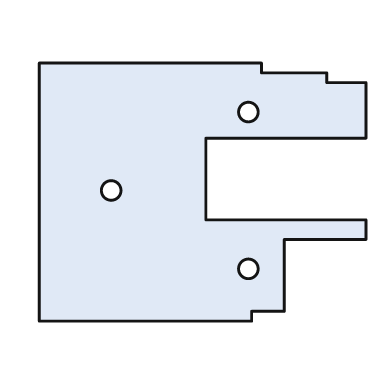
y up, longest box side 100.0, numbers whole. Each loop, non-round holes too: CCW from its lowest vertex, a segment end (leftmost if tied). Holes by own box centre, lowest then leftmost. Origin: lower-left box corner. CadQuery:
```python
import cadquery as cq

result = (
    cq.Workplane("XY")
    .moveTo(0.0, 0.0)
    .lineTo(65.0, 0.0)
    .lineTo(65.0, 3.0)
    .lineTo(75.0, 3.0)
    .lineTo(75.0, 25.0)
    .lineTo(100.0, 25.0)
    .lineTo(100.0, 31.0)
    .lineTo(51.0, 31.0)
    .lineTo(51.0, 56.0)
    .lineTo(100.0, 56.0)
    .lineTo(100.0, 73.0)
    .lineTo(88.0, 73.0)
    .lineTo(88.0, 76.0)
    .lineTo(68.0, 76.0)
    .lineTo(68.0, 79.0)
    .lineTo(0.0, 79.0)
    .close()
    .moveTo(64.0, 16.0)
    .circle(3.0)
    .moveTo(22.0, 40.0)
    .circle(3.0)
    .moveTo(64.0, 64.0)
    .circle(3.0)
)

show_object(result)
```